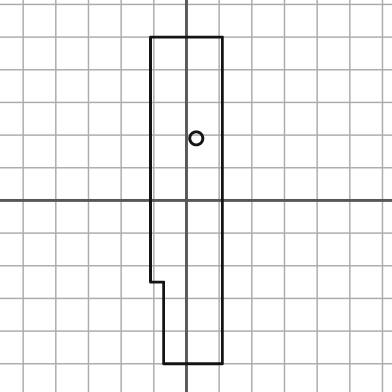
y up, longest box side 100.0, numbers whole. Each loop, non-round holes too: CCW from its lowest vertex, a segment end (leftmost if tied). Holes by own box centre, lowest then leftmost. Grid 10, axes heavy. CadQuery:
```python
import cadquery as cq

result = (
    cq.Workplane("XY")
    .moveTo(-7.0, -50.0)
    .lineTo(11.0, -50.0)
    .lineTo(11.0, 50.0)
    .lineTo(-11.0, 50.0)
    .lineTo(-11.0, -25.0)
    .lineTo(-7.0, -25.0)
    .close()
    .moveTo(3.0, 19.0)
    .circle(2.0)
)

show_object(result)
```